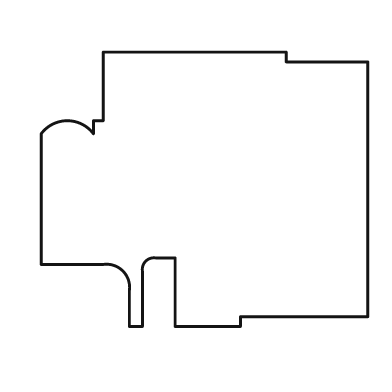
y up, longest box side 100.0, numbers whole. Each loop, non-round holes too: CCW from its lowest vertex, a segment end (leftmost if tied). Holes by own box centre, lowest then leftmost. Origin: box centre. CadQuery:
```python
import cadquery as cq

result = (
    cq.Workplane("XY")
    .moveTo(-23.0, -42.0)
    .lineTo(-19.0, -42.0)
    .lineTo(-19.0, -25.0)
    .threePointArc((-18.0, -22.0), (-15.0, -21.0))
    .lineTo(-9.0, -21.0)
    .lineTo(-9.0, -42.0)
    .lineTo(11.0, -42.0)
    .lineTo(11.0, -39.0)
    .lineTo(50.0, -39.0)
    .lineTo(50.0, 39.0)
    .lineTo(25.0, 39.0)
    .lineTo(25.0, 42.0)
    .lineTo(-31.0, 42.0)
    .lineTo(-31.0, 21.0)
    .lineTo(-34.0, 21.0)
    .lineTo(-34.0, 17.0)
    .threePointArc((-42.0, 21.0), (-50.0, 17.0))
    .lineTo(-50.0, -23.0)
    .lineTo(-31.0, -23.0)
    .threePointArc((-25.0, -25.0), (-23.0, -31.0))
    .close()
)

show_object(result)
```